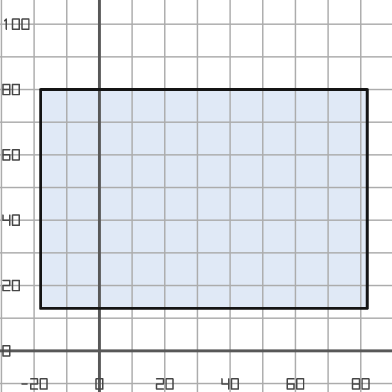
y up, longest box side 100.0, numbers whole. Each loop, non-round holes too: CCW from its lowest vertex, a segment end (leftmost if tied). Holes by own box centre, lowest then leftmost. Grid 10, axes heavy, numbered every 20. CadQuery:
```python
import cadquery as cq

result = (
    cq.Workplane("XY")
    .moveTo(-18.0, 13.0)
    .lineTo(82.0, 13.0)
    .lineTo(82.0, 80.0)
    .lineTo(-18.0, 80.0)
    .close()
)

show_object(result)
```